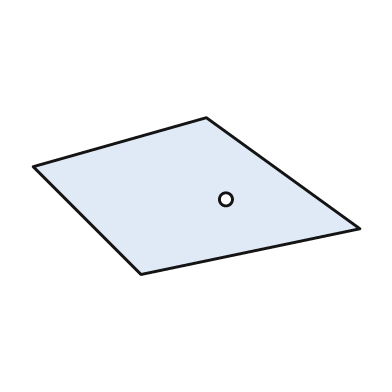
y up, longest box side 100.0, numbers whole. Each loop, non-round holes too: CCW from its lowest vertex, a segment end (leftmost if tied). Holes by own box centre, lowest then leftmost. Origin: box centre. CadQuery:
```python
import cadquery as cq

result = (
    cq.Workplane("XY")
    .moveTo(-17.0, -24.0)
    .lineTo(50.0, -10.0)
    .lineTo(3.0, 24.0)
    .lineTo(-50.0, 9.0)
    .close()
    .moveTo(9.0, -1.0)
    .circle(2.0)
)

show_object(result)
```